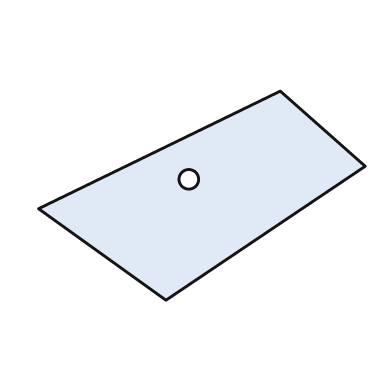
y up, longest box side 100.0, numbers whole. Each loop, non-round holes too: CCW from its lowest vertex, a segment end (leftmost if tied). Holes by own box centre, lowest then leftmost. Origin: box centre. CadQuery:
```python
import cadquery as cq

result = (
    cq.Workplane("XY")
    .moveTo(-11.0, -32.0)
    .lineTo(50.0, 9.0)
    .lineTo(24.0, 32.0)
    .lineTo(-50.0, -4.0)
    .close()
    .moveTo(-4.0, 5.0)
    .circle(3.0)
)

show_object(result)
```